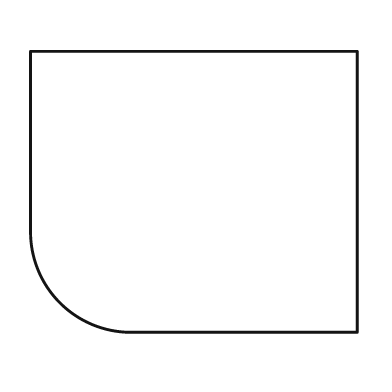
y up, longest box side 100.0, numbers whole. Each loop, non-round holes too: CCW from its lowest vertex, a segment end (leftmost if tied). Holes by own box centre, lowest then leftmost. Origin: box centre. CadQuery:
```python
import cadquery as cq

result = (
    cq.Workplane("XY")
    .moveTo(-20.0, -43.0)
    .lineTo(50.0, -43.0)
    .lineTo(50.0, 43.0)
    .lineTo(-50.0, 43.0)
    .lineTo(-50.0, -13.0)
    .threePointArc((-41.0, -34.0), (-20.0, -43.0))
    .close()
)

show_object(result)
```